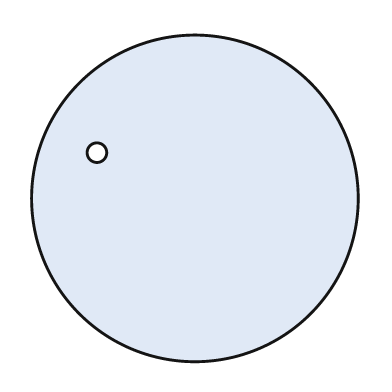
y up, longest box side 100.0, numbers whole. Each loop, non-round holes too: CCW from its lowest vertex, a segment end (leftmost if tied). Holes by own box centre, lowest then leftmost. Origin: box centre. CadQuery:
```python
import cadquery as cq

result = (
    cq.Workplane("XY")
    .moveTo(0.0, 0.0)
    .circle(50.0)
    .moveTo(-30.0, 14.0)
    .circle(3.0)
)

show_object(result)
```